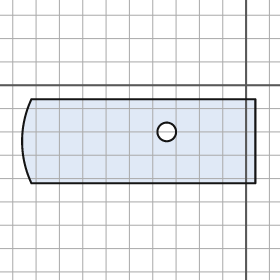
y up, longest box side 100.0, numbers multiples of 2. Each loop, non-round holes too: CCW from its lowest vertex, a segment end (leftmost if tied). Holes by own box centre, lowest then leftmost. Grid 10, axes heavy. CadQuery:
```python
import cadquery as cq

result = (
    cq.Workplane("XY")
    .moveTo(-92.0, -42.0)
    .lineTo(4.0, -42.0)
    .lineTo(4.0, -6.0)
    .lineTo(-92.0, -6.0)
    .threePointArc((-96.0, -24.0), (-92.0, -42.0))
    .close()
    .moveTo(-34.0, -20.0)
    .circle(4.0)
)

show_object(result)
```